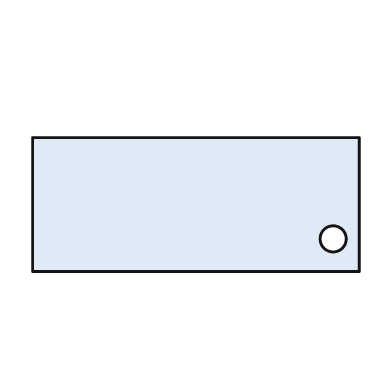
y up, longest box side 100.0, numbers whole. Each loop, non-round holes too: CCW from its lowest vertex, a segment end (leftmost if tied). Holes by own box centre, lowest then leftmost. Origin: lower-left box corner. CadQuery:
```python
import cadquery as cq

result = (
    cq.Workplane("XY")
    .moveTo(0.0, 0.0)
    .lineTo(100.0, 0.0)
    .lineTo(100.0, 41.0)
    .lineTo(0.0, 41.0)
    .close()
    .moveTo(92.0, 10.0)
    .circle(4.0)
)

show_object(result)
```